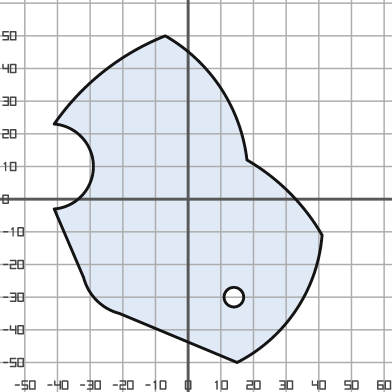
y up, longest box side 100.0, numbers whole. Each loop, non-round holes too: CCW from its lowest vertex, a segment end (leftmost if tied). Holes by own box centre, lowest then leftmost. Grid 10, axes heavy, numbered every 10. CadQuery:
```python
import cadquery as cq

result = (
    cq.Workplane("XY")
    .moveTo(15.0, -50.0)
    .threePointArc((33.0, -34.0), (41.0, -11.0))
    .threePointArc((31.0, 2.0), (18.0, 12.0))
    .threePointArc((10.0, 34.0), (-7.0, 50.0))
    .threePointArc((-26.0, 39.0), (-41.0, 23.0))
    .threePointArc((-29.0, 10.0), (-41.0, -3.0))
    .lineTo(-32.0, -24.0)
    .threePointArc((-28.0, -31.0), (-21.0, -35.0))
    .close()
    .moveTo(14.0, -30.0)
    .circle(3.0)
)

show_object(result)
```